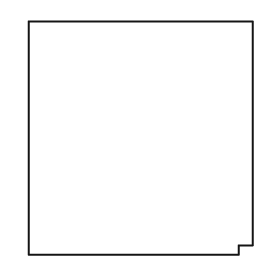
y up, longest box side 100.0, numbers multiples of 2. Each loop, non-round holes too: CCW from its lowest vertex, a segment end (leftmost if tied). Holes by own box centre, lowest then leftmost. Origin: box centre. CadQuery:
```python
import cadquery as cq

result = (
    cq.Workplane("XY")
    .moveTo(-48.0, -50.0)
    .lineTo(42.0, -50.0)
    .lineTo(42.0, -46.0)
    .lineTo(48.0, -46.0)
    .lineTo(48.0, 50.0)
    .lineTo(-48.0, 50.0)
    .close()
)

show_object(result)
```